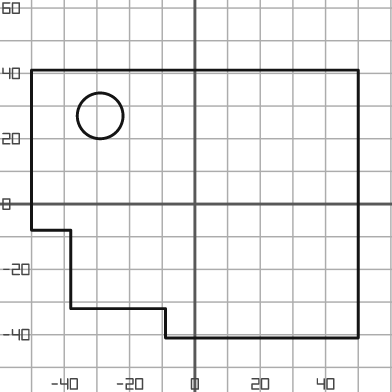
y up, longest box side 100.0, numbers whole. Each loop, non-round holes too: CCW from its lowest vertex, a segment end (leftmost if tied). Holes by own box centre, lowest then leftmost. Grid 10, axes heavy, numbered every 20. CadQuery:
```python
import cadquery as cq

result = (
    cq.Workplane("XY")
    .moveTo(-9.0, -41.0)
    .lineTo(50.0, -41.0)
    .lineTo(50.0, 41.0)
    .lineTo(-50.0, 41.0)
    .lineTo(-50.0, -8.0)
    .lineTo(-38.0, -8.0)
    .lineTo(-38.0, -32.0)
    .lineTo(-9.0, -32.0)
    .close()
    .moveTo(-29.0, 27.0)
    .circle(7.0)
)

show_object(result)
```